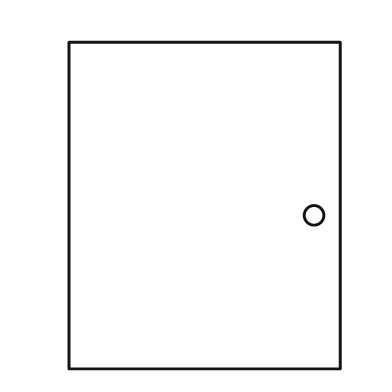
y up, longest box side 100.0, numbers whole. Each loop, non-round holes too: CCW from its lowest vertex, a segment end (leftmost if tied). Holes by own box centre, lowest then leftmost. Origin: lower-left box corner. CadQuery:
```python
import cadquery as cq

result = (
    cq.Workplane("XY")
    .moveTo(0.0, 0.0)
    .lineTo(83.0, 0.0)
    .lineTo(83.0, 100.0)
    .lineTo(0.0, 100.0)
    .close()
    .moveTo(75.0, 47.0)
    .circle(3.0)
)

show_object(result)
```